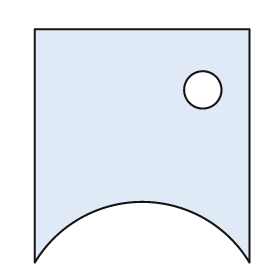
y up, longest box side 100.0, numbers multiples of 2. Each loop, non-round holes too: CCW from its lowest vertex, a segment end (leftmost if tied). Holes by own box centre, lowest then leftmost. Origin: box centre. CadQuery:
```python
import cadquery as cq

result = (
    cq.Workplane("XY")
    .moveTo(-46.0, -50.0)
    .threePointArc((0.0, -24.0), (46.0, -50.0))
    .lineTo(46.0, 50.0)
    .lineTo(-46.0, 50.0)
    .close()
    .moveTo(26.0, 24.0)
    .circle(8.0)
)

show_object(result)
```